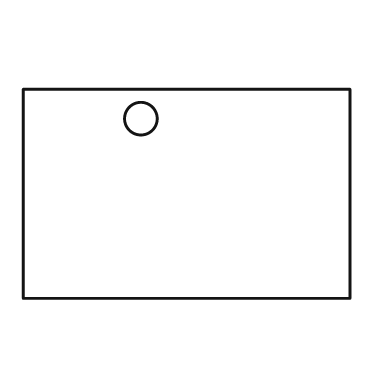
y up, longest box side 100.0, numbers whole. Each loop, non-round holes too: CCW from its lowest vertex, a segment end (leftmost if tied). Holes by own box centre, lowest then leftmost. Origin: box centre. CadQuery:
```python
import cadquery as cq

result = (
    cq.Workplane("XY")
    .moveTo(-50.0, -32.0)
    .lineTo(50.0, -32.0)
    .lineTo(50.0, 32.0)
    .lineTo(-50.0, 32.0)
    .close()
    .moveTo(-14.0, 23.0)
    .circle(5.0)
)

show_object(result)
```